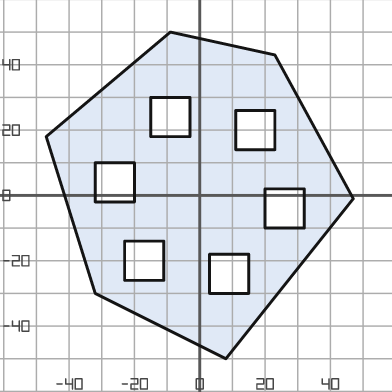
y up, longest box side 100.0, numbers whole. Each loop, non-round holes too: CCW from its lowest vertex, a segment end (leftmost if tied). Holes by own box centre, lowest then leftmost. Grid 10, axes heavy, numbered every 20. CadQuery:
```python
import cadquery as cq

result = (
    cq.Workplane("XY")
    .moveTo(8.0, -50.0)
    .lineTo(47.0, -1.0)
    .lineTo(23.0, 43.0)
    .lineTo(-9.0, 50.0)
    .lineTo(-47.0, 18.0)
    .lineTo(-32.0, -30.0)
    .close()
    .moveTo(3.0, -30.0)
    .lineTo(15.0, -30.0)
    .lineTo(15.0, -18.0)
    .lineTo(3.0, -18.0)
    .close()
    .moveTo(-23.0, -26.0)
    .lineTo(-11.0, -26.0)
    .lineTo(-11.0, -14.0)
    .lineTo(-23.0, -14.0)
    .close()
    .moveTo(20.0, -10.0)
    .lineTo(32.0, -10.0)
    .lineTo(32.0, 2.0)
    .lineTo(20.0, 2.0)
    .close()
    .moveTo(-32.0, -2.0)
    .lineTo(-20.0, -2.0)
    .lineTo(-20.0, 10.0)
    .lineTo(-32.0, 10.0)
    .close()
    .moveTo(11.0, 14.0)
    .lineTo(23.0, 14.0)
    .lineTo(23.0, 26.0)
    .lineTo(11.0, 26.0)
    .close()
    .moveTo(-15.0, 18.0)
    .lineTo(-3.0, 18.0)
    .lineTo(-3.0, 30.0)
    .lineTo(-15.0, 30.0)
    .close()
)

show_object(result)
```